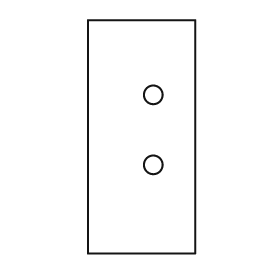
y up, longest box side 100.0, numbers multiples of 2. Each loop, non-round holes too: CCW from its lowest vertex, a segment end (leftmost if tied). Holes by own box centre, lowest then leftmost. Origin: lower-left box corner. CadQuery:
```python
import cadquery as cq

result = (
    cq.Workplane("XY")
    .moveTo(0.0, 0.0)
    .lineTo(46.0, 0.0)
    .lineTo(46.0, 100.0)
    .lineTo(0.0, 100.0)
    .close()
    .moveTo(28.0, 38.0)
    .circle(4.0)
    .moveTo(28.0, 68.0)
    .circle(4.0)
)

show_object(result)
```